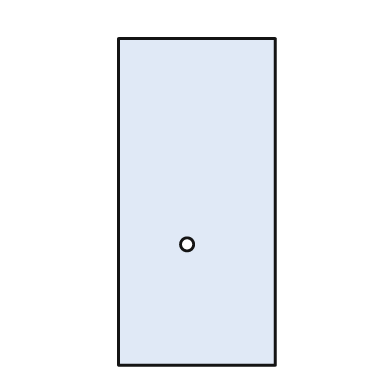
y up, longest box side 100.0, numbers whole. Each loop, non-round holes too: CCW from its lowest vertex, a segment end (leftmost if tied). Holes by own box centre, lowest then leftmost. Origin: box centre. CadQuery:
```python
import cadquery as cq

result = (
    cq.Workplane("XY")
    .moveTo(-24.0, -50.0)
    .lineTo(24.0, -50.0)
    .lineTo(24.0, 50.0)
    .lineTo(-24.0, 50.0)
    .close()
    .moveTo(-3.0, -13.0)
    .circle(2.0)
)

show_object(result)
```